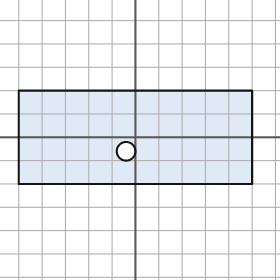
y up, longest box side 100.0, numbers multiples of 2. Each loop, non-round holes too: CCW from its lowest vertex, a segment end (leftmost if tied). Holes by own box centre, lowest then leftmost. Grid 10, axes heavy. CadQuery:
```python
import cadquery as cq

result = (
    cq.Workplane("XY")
    .moveTo(-50.0, -20.0)
    .lineTo(50.0, -20.0)
    .lineTo(50.0, 20.0)
    .lineTo(-50.0, 20.0)
    .close()
    .moveTo(-4.0, -6.0)
    .circle(4.0)
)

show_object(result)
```